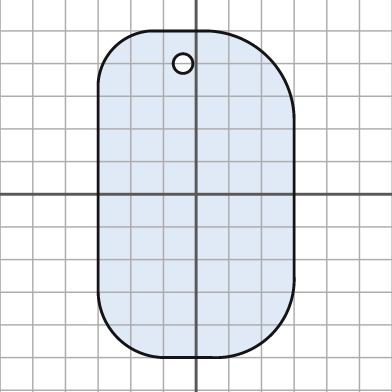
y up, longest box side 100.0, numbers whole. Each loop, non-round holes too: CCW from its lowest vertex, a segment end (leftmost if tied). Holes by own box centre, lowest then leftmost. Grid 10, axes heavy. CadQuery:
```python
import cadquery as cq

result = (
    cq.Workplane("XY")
    .moveTo(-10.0, -50.0)
    .lineTo(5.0, -50.0)
    .threePointArc((23.0, -43.0), (30.0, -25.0))
    .lineTo(30.0, 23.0)
    .threePointArc((22.0, 42.0), (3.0, 50.0))
    .lineTo(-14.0, 50.0)
    .threePointArc((-25.0, 45.0), (-30.0, 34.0))
    .lineTo(-30.0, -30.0)
    .threePointArc((-24.0, -44.0), (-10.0, -50.0))
    .close()
    .moveTo(-4.0, 40.0)
    .circle(3.0)
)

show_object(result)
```